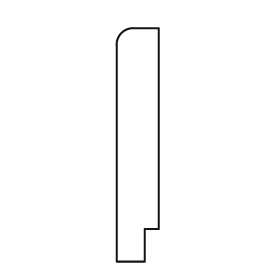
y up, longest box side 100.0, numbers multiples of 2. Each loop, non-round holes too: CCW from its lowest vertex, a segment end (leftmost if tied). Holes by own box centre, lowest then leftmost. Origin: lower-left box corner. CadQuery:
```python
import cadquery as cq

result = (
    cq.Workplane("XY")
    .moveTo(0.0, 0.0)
    .lineTo(12.0, 0.0)
    .lineTo(12.0, 14.0)
    .lineTo(18.0, 14.0)
    .lineTo(18.0, 100.0)
    .lineTo(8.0, 100.0)
    .threePointArc((2.0, 98.0), (0.0, 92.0))
    .close()
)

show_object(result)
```